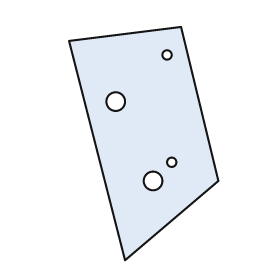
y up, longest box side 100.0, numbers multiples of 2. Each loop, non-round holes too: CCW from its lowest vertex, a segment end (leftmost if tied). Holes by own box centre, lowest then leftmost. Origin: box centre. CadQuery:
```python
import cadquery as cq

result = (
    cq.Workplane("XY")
    .moveTo(-8.0, -50.0)
    .lineTo(32.0, -16.0)
    .lineTo(16.0, 50.0)
    .lineTo(-32.0, 44.0)
    .close()
    .moveTo(4.0, -16.0)
    .circle(4.0)
    .moveTo(12.0, -8.0)
    .circle(2.0)
    .moveTo(-12.0, 18.0)
    .circle(4.0)
    .moveTo(10.0, 38.0)
    .circle(2.0)
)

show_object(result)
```